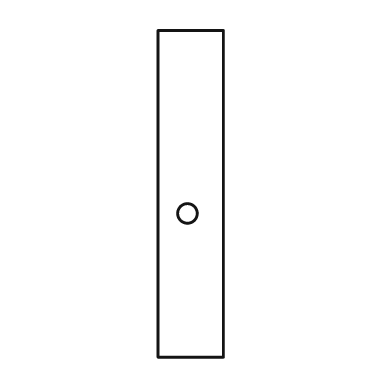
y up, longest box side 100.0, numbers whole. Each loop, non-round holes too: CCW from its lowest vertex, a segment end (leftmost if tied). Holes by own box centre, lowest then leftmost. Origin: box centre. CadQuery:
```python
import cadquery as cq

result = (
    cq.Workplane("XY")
    .moveTo(-10.0, -50.0)
    .lineTo(10.0, -50.0)
    .lineTo(10.0, 50.0)
    .lineTo(-10.0, 50.0)
    .close()
    .moveTo(-1.0, -6.0)
    .circle(3.0)
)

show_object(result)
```